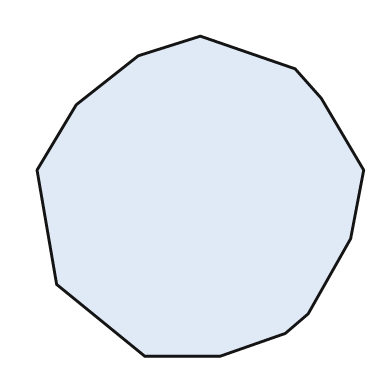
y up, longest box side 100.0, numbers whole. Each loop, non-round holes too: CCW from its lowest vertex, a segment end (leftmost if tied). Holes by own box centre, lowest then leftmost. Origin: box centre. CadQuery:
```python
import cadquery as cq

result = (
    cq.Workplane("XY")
    .moveTo(-17.0, -49.0)
    .lineTo(6.0, -49.0)
    .lineTo(26.0, -42.0)
    .lineTo(33.0, -36.0)
    .lineTo(46.0, -13.0)
    .lineTo(50.0, 8.0)
    .lineTo(37.0, 30.0)
    .lineTo(29.0, 39.0)
    .lineTo(0.0, 49.0)
    .lineTo(-19.0, 43.0)
    .lineTo(-38.0, 28.0)
    .lineTo(-50.0, 8.0)
    .lineTo(-44.0, -27.0)
    .close()
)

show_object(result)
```